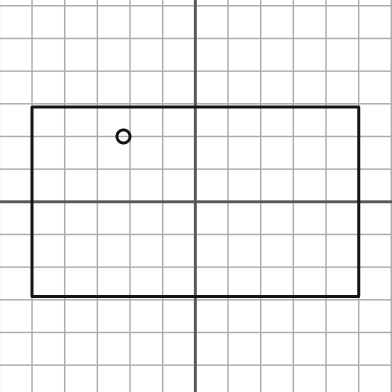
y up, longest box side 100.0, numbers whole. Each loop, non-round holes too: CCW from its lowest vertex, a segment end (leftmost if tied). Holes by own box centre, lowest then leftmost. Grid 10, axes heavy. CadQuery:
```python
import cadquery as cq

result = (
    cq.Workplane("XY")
    .moveTo(-50.0, -29.0)
    .lineTo(50.0, -29.0)
    .lineTo(50.0, 29.0)
    .lineTo(-50.0, 29.0)
    .close()
    .moveTo(-22.0, 20.0)
    .circle(2.0)
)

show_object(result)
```